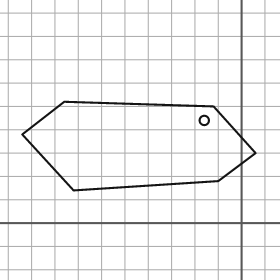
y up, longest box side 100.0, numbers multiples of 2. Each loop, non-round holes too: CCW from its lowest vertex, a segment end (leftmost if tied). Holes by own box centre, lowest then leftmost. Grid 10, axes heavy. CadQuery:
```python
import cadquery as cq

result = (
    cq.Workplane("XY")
    .moveTo(-72.0, 14.0)
    .lineTo(-10.0, 18.0)
    .lineTo(6.0, 30.0)
    .lineTo(-12.0, 50.0)
    .lineTo(-76.0, 52.0)
    .lineTo(-94.0, 38.0)
    .close()
    .moveTo(-16.0, 44.0)
    .circle(2.0)
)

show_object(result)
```